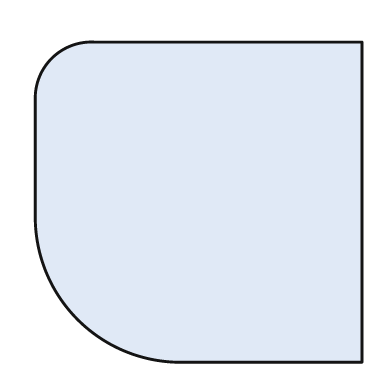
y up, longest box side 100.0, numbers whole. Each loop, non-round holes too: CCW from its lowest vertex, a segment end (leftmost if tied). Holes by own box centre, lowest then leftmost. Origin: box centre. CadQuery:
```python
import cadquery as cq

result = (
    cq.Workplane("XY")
    .moveTo(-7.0, -49.0)
    .lineTo(50.0, -49.0)
    .lineTo(50.0, 49.0)
    .lineTo(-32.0, 49.0)
    .threePointArc((-45.0, 44.0), (-50.0, 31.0))
    .lineTo(-50.0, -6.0)
    .threePointArc((-37.0, -36.0), (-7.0, -49.0))
    .close()
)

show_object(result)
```